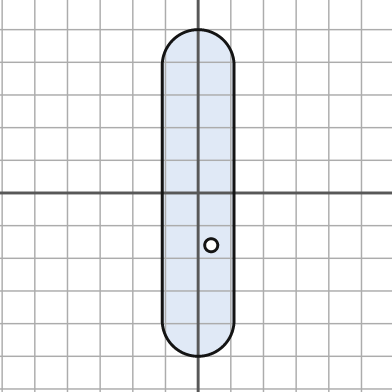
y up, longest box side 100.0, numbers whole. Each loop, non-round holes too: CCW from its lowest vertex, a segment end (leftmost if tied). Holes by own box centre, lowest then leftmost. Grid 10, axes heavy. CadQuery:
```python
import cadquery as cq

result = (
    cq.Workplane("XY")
    .moveTo(-11.0, -39.0)
    .threePointArc((0.0, -50.0), (11.0, -39.0))
    .lineTo(11.0, 39.0)
    .threePointArc((0.0, 50.0), (-11.0, 39.0))
    .close()
    .moveTo(4.0, -16.0)
    .circle(2.0)
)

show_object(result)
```